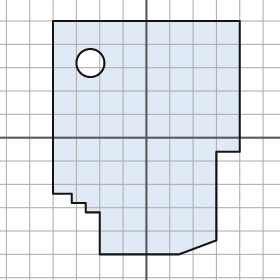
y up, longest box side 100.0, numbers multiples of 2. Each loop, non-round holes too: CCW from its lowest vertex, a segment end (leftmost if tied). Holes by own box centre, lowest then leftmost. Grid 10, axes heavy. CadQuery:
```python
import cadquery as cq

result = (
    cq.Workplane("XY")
    .moveTo(-20.0, -50.0)
    .lineTo(14.0, -50.0)
    .lineTo(30.0, -44.0)
    .lineTo(30.0, -6.0)
    .lineTo(40.0, -6.0)
    .lineTo(40.0, 50.0)
    .lineTo(-40.0, 50.0)
    .lineTo(-40.0, -24.0)
    .lineTo(-32.0, -24.0)
    .lineTo(-32.0, -28.0)
    .lineTo(-26.0, -28.0)
    .lineTo(-26.0, -32.0)
    .lineTo(-20.0, -32.0)
    .close()
    .moveTo(-24.0, 32.0)
    .circle(6.0)
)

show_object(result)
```